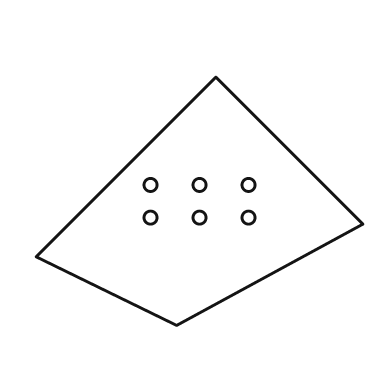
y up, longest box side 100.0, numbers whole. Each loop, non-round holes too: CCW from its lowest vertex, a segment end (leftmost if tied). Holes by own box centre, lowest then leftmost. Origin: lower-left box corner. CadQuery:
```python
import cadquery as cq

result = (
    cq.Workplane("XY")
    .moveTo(43.0, 0.0)
    .lineTo(100.0, 31.0)
    .lineTo(55.0, 76.0)
    .lineTo(0.0, 21.0)
    .close()
    .moveTo(35.0, 33.0)
    .circle(2.0)
    .moveTo(50.0, 33.0)
    .circle(2.0)
    .moveTo(65.0, 33.0)
    .circle(2.0)
    .moveTo(35.0, 43.0)
    .circle(2.0)
    .moveTo(50.0, 43.0)
    .circle(2.0)
    .moveTo(65.0, 43.0)
    .circle(2.0)
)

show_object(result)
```